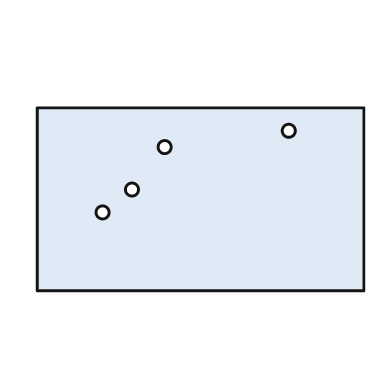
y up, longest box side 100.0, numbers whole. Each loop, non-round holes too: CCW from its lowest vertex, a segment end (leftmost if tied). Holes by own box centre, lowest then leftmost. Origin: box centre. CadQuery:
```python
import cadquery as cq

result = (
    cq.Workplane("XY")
    .moveTo(-50.0, -28.0)
    .lineTo(50.0, -28.0)
    .lineTo(50.0, 28.0)
    .lineTo(-50.0, 28.0)
    .close()
    .moveTo(-30.0, -4.0)
    .circle(2.0)
    .moveTo(-21.0, 3.0)
    .circle(2.0)
    .moveTo(-11.0, 16.0)
    .circle(2.0)
    .moveTo(27.0, 21.0)
    .circle(2.0)
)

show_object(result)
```